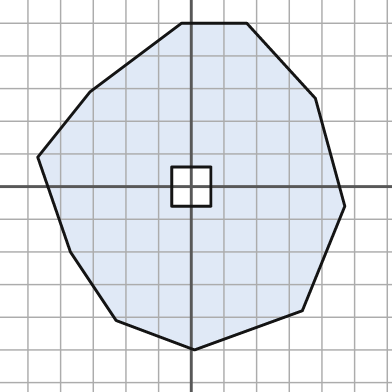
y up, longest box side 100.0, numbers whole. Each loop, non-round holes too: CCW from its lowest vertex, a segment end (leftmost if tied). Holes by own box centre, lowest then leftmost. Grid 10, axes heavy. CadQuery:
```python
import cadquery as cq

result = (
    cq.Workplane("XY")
    .moveTo(1.0, -50.0)
    .lineTo(34.0, -38.0)
    .lineTo(47.0, -6.0)
    .lineTo(38.0, 27.0)
    .lineTo(17.0, 50.0)
    .lineTo(-3.0, 50.0)
    .lineTo(-31.0, 29.0)
    .lineTo(-47.0, 9.0)
    .lineTo(-37.0, -20.0)
    .lineTo(-23.0, -41.0)
    .close()
    .moveTo(-6.0, -6.0)
    .lineTo(6.0, -6.0)
    .lineTo(6.0, 6.0)
    .lineTo(-6.0, 6.0)
    .close()
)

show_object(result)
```